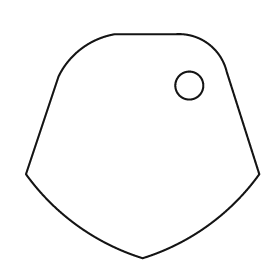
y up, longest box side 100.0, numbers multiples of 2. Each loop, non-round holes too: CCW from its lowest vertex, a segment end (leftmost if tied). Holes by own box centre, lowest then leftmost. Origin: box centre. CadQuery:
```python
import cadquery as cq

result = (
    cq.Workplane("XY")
    .moveTo(0.0, -48.0)
    .threePointArc((28.0, -34.0), (50.0, -12.0))
    .lineTo(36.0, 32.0)
    .threePointArc((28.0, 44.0), (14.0, 48.0))
    .lineTo(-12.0, 48.0)
    .threePointArc((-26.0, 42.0), (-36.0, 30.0))
    .lineTo(-50.0, -12.0)
    .threePointArc((-28.0, -34.0), (0.0, -48.0))
    .close()
    .moveTo(20.0, 26.0)
    .circle(6.0)
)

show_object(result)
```